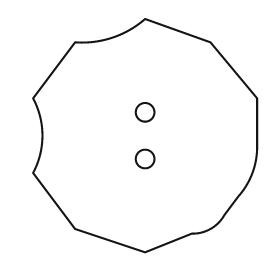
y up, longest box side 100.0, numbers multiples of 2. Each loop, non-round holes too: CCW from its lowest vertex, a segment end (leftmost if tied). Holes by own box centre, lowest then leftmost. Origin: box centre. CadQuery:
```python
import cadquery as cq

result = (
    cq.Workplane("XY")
    .moveTo(0.0, -50.0)
    .lineTo(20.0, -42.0)
    .threePointArc((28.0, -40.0), (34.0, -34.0))
    .lineTo(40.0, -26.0)
    .threePointArc((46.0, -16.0), (48.0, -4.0))
    .lineTo(48.0, 16.0)
    .lineTo(28.0, 40.0)
    .lineTo(0.0, 50.0)
    .threePointArc((-14.0, 42.0), (-30.0, 40.0))
    .lineTo(-48.0, 16.0)
    .threePointArc((-44.0, 0.0), (-48.0, -16.0))
    .lineTo(-30.0, -40.0)
    .close()
    .moveTo(0.0, -10.0)
    .circle(4.0)
    .moveTo(0.0, 10.0)
    .circle(4.0)
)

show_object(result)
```